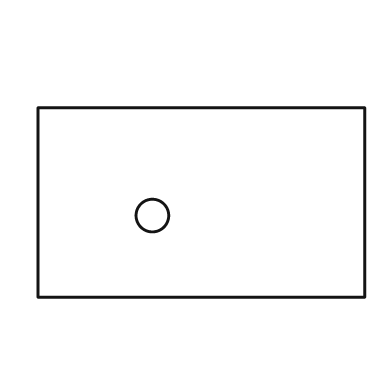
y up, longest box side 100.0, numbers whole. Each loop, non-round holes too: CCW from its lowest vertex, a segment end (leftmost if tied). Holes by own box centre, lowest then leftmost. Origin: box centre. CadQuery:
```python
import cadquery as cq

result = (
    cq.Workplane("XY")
    .moveTo(-50.0, -29.0)
    .lineTo(50.0, -29.0)
    .lineTo(50.0, 29.0)
    .lineTo(-50.0, 29.0)
    .close()
    .moveTo(-15.0, -4.0)
    .circle(5.0)
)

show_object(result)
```